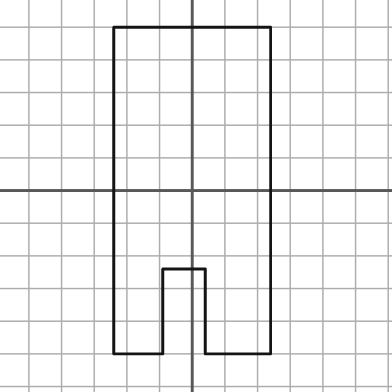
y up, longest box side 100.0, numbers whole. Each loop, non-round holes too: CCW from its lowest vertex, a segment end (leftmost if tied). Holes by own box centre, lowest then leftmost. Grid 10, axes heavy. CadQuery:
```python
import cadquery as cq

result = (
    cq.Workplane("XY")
    .moveTo(-24.0, -50.0)
    .lineTo(-9.0, -50.0)
    .lineTo(-9.0, -24.0)
    .lineTo(4.0, -24.0)
    .lineTo(4.0, -50.0)
    .lineTo(24.0, -50.0)
    .lineTo(24.0, 50.0)
    .lineTo(-24.0, 50.0)
    .close()
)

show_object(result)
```